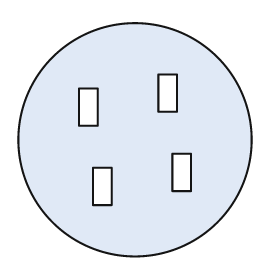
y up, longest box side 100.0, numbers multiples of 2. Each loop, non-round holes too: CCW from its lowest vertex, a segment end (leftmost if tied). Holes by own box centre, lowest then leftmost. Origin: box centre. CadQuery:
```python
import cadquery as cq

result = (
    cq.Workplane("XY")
    .moveTo(0.0, 0.0)
    .circle(50.0)
    .moveTo(-18.0, -28.0)
    .lineTo(-10.0, -28.0)
    .lineTo(-10.0, -12.0)
    .lineTo(-18.0, -12.0)
    .close()
    .moveTo(16.0, -22.0)
    .lineTo(24.0, -22.0)
    .lineTo(24.0, -6.0)
    .lineTo(16.0, -6.0)
    .close()
    .moveTo(-24.0, 6.0)
    .lineTo(-16.0, 6.0)
    .lineTo(-16.0, 22.0)
    .lineTo(-24.0, 22.0)
    .close()
    .moveTo(10.0, 12.0)
    .lineTo(18.0, 12.0)
    .lineTo(18.0, 28.0)
    .lineTo(10.0, 28.0)
    .close()
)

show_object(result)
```